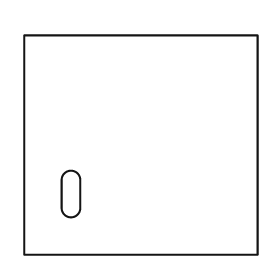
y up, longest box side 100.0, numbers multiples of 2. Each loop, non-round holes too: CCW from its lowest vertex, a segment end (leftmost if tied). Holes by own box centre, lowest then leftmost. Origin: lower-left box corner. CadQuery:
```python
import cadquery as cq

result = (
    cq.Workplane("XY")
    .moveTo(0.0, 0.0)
    .lineTo(100.0, 0.0)
    .lineTo(100.0, 94.0)
    .lineTo(0.0, 94.0)
    .close()
    .moveTo(16.0, 20.0)
    .threePointArc((20.0, 16.0), (24.0, 20.0))
    .lineTo(24.0, 32.0)
    .threePointArc((20.0, 36.0), (16.0, 32.0))
    .close()
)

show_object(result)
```